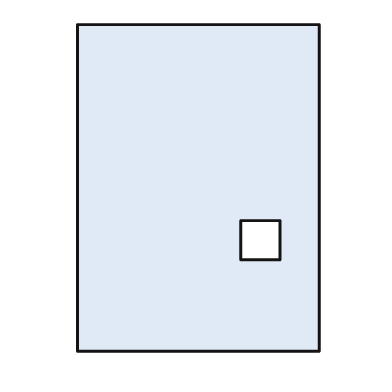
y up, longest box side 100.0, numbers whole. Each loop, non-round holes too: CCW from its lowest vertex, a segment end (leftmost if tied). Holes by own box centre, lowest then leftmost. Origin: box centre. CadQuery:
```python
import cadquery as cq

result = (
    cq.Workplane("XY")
    .moveTo(-37.0, -50.0)
    .lineTo(37.0, -50.0)
    .lineTo(37.0, 50.0)
    .lineTo(-37.0, 50.0)
    .close()
    .moveTo(13.0, -22.0)
    .lineTo(25.0, -22.0)
    .lineTo(25.0, -10.0)
    .lineTo(13.0, -10.0)
    .close()
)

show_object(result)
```